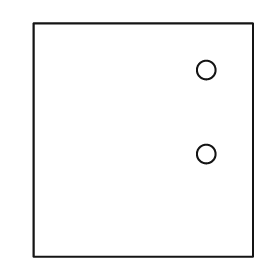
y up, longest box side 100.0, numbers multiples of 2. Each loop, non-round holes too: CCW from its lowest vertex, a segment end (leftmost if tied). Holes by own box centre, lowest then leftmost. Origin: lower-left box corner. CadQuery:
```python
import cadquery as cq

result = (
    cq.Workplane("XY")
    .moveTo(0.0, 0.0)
    .lineTo(94.0, 0.0)
    .lineTo(94.0, 100.0)
    .lineTo(0.0, 100.0)
    .close()
    .moveTo(74.0, 44.0)
    .circle(4.0)
    .moveTo(74.0, 80.0)
    .circle(4.0)
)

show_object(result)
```